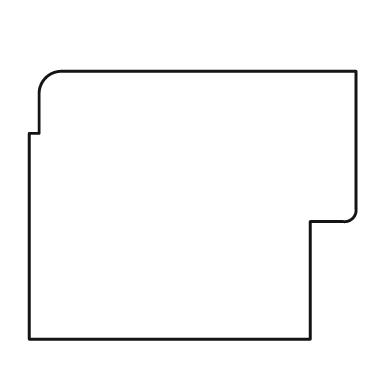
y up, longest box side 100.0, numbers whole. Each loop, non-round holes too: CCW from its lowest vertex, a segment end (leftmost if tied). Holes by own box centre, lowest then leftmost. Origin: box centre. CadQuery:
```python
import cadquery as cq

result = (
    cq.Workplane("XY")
    .moveTo(-50.0, -41.0)
    .lineTo(36.0, -41.0)
    .lineTo(36.0, -5.0)
    .lineTo(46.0, -5.0)
    .threePointArc((49.0, -4.0), (50.0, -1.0))
    .lineTo(50.0, 41.0)
    .lineTo(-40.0, 41.0)
    .threePointArc((-45.0, 39.0), (-47.0, 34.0))
    .lineTo(-47.0, 22.0)
    .lineTo(-50.0, 22.0)
    .close()
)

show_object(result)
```